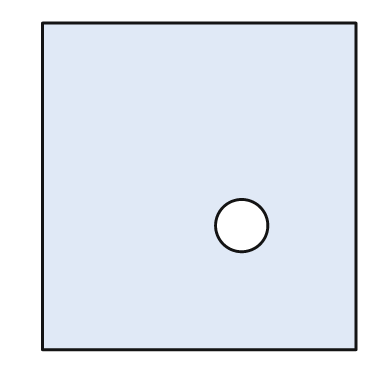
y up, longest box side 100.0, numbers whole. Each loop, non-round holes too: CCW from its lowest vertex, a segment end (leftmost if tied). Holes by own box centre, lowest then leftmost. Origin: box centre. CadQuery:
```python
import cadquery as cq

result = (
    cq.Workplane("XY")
    .moveTo(-48.0, -50.0)
    .lineTo(48.0, -50.0)
    .lineTo(48.0, 50.0)
    .lineTo(-48.0, 50.0)
    .close()
    .moveTo(13.0, -12.0)
    .circle(8.0)
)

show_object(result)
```